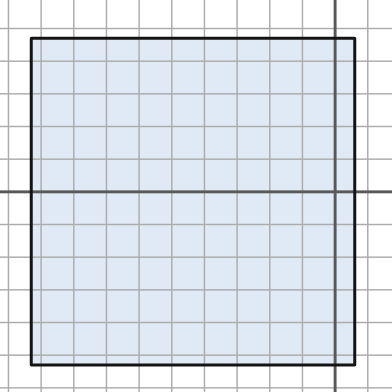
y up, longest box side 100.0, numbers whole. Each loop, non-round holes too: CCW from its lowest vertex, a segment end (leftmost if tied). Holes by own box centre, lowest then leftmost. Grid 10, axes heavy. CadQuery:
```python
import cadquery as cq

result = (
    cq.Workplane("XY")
    .moveTo(-93.0, -53.0)
    .lineTo(6.0, -53.0)
    .lineTo(6.0, 47.0)
    .lineTo(-93.0, 47.0)
    .close()
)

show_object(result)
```